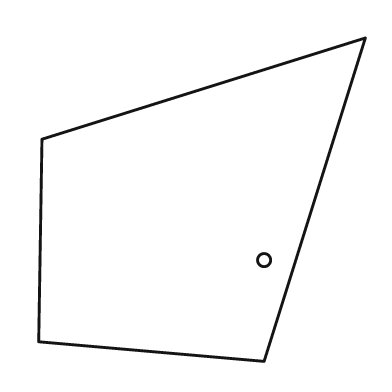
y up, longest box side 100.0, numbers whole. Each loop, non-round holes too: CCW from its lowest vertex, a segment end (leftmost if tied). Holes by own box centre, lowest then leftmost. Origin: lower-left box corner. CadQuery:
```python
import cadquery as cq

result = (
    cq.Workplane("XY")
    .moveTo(69.0, 0.0)
    .lineTo(100.0, 99.0)
    .lineTo(1.0, 68.0)
    .lineTo(0.0, 6.0)
    .close()
    .moveTo(69.0, 31.0)
    .circle(2.0)
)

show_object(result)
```